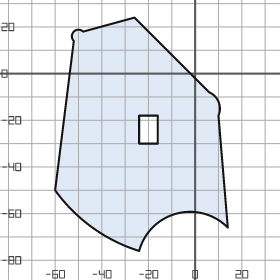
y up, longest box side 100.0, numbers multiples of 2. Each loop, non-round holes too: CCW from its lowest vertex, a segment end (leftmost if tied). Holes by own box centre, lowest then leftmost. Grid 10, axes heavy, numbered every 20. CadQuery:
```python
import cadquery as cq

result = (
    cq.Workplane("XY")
    .moveTo(-24.0, -76.0)
    .threePointArc((-8.0, -60.0), (14.0, -66.0))
    .lineTo(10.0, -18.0)
    .threePointArc((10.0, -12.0), (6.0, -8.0))
    .lineTo(-26.0, 24.0)
    .lineTo(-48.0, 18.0)
    .threePointArc((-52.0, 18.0), (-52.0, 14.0))
    .lineTo(-60.0, -50.0)
    .threePointArc((-44.0, -66.0), (-24.0, -76.0))
    .close()
    .moveTo(-24.0, -30.0)
    .lineTo(-16.0, -30.0)
    .lineTo(-16.0, -18.0)
    .lineTo(-24.0, -18.0)
    .close()
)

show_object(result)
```